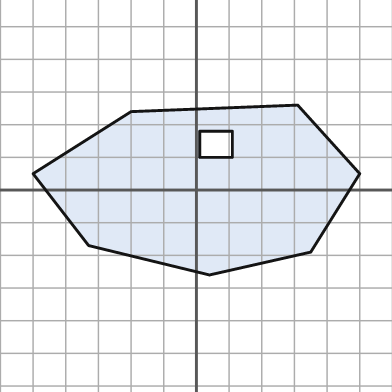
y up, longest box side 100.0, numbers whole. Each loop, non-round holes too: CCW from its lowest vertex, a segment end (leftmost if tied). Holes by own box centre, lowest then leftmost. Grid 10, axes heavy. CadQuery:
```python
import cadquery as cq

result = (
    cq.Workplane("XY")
    .moveTo(4.0, -26.0)
    .lineTo(35.0, -19.0)
    .lineTo(50.0, 5.0)
    .lineTo(31.0, 26.0)
    .lineTo(-20.0, 24.0)
    .lineTo(-50.0, 5.0)
    .lineTo(-33.0, -17.0)
    .close()
    .moveTo(1.0, 10.0)
    .lineTo(11.0, 10.0)
    .lineTo(11.0, 18.0)
    .lineTo(1.0, 18.0)
    .close()
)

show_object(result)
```